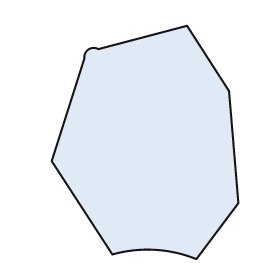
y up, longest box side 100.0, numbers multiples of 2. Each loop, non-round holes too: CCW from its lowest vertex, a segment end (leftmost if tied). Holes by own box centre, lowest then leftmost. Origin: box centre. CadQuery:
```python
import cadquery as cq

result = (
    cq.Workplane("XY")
    .moveTo(22.0, -50.0)
    .lineTo(40.0, -26.0)
    .lineTo(36.0, 22.0)
    .lineTo(18.0, 50.0)
    .lineTo(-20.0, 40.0)
    .threePointArc((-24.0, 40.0), (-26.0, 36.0))
    .lineTo(-40.0, -8.0)
    .lineTo(-14.0, -48.0)
    .threePointArc((4.0, -46.0), (22.0, -50.0))
    .close()
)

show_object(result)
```